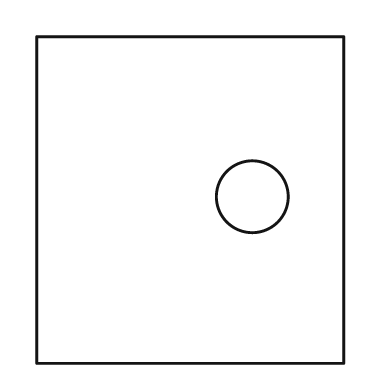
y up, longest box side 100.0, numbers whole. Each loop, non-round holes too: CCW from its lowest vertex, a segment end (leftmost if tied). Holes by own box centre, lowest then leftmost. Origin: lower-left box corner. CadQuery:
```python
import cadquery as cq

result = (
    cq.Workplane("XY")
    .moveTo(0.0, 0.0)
    .lineTo(94.0, 0.0)
    .lineTo(94.0, 100.0)
    .lineTo(0.0, 100.0)
    .close()
    .moveTo(66.0, 51.0)
    .circle(11.0)
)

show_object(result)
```